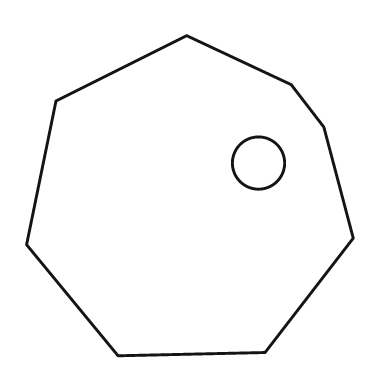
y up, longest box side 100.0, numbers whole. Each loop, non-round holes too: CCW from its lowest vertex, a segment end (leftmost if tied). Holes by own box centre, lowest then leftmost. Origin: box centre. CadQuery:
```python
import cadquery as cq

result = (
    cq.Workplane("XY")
    .moveTo(-22.0, -49.0)
    .lineTo(23.0, -48.0)
    .lineTo(50.0, -13.0)
    .lineTo(41.0, 21.0)
    .lineTo(31.0, 34.0)
    .lineTo(-1.0, 49.0)
    .lineTo(-41.0, 29.0)
    .lineTo(-50.0, -15.0)
    .close()
    .moveTo(21.0, 10.0)
    .circle(8.0)
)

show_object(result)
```